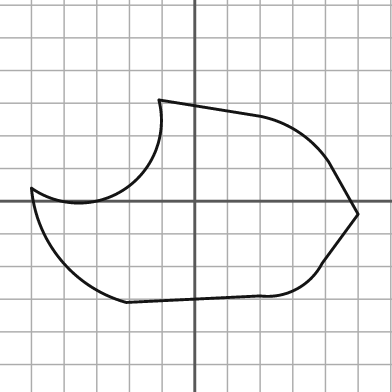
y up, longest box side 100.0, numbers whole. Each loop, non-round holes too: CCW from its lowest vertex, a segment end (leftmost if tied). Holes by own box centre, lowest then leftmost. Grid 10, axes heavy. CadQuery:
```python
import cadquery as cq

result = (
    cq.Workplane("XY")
    .moveTo(-21.0, -31.0)
    .lineTo(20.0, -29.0)
    .threePointArc((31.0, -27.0), (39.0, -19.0))
    .lineTo(50.0, -4.0)
    .lineTo(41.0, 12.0)
    .threePointArc((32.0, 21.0), (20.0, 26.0))
    .lineTo(-11.0, 31.0)
    .threePointArc((-21.0, 4.0), (-50.0, 4.0))
    .threePointArc((-41.0, -18.0), (-21.0, -31.0))
    .close()
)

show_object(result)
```